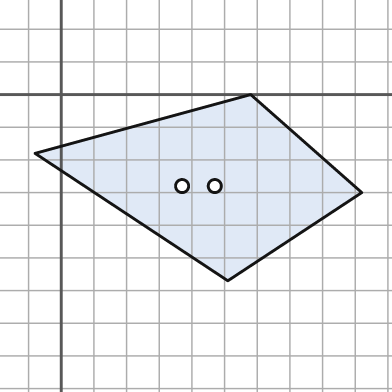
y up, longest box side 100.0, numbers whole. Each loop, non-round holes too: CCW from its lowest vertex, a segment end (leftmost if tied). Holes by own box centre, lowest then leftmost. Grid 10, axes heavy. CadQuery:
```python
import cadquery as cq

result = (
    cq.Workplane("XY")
    .moveTo(51.0, -57.0)
    .lineTo(92.0, -30.0)
    .lineTo(58.0, 0.0)
    .lineTo(-8.0, -18.0)
    .close()
    .moveTo(37.0, -28.0)
    .circle(2.0)
    .moveTo(47.0, -28.0)
    .circle(2.0)
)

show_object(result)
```